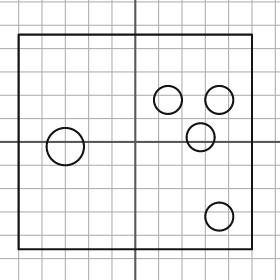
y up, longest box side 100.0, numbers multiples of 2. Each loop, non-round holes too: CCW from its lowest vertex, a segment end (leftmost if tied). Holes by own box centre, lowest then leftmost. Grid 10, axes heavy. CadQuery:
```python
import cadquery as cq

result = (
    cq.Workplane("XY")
    .moveTo(-50.0, -46.0)
    .lineTo(50.0, -46.0)
    .lineTo(50.0, 46.0)
    .lineTo(-50.0, 46.0)
    .close()
    .moveTo(36.0, -32.0)
    .circle(6.0)
    .moveTo(-30.0, -2.0)
    .circle(8.0)
    .moveTo(28.0, 2.0)
    .circle(6.0)
    .moveTo(14.0, 18.0)
    .circle(6.0)
    .moveTo(36.0, 18.0)
    .circle(6.0)
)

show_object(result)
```